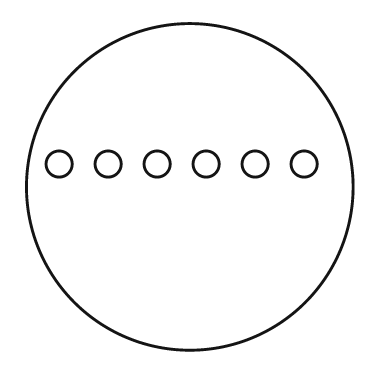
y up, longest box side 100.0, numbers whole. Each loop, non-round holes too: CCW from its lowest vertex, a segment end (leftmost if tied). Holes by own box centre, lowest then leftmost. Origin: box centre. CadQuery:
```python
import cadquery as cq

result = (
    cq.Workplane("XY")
    .moveTo(0.0, 0.0)
    .circle(50.0)
    .moveTo(-40.0, 7.0)
    .circle(4.0)
    .moveTo(-25.0, 7.0)
    .circle(4.0)
    .moveTo(-10.0, 7.0)
    .circle(4.0)
    .moveTo(5.0, 7.0)
    .circle(4.0)
    .moveTo(20.0, 7.0)
    .circle(4.0)
    .moveTo(35.0, 7.0)
    .circle(4.0)
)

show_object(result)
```